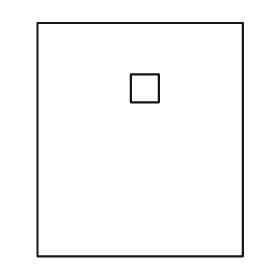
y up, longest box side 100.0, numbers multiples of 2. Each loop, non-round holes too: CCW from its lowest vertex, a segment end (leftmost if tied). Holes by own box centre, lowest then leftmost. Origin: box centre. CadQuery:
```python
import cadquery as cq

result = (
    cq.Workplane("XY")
    .moveTo(-44.0, -50.0)
    .lineTo(44.0, -50.0)
    .lineTo(44.0, 50.0)
    .lineTo(-44.0, 50.0)
    .close()
    .moveTo(-4.0, 16.0)
    .lineTo(8.0, 16.0)
    .lineTo(8.0, 28.0)
    .lineTo(-4.0, 28.0)
    .close()
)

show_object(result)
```